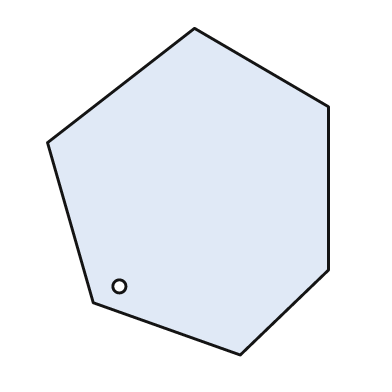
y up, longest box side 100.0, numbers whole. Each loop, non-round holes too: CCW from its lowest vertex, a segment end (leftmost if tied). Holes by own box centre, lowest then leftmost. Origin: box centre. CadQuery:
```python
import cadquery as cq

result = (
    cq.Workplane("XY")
    .moveTo(16.0, -50.0)
    .lineTo(43.0, -24.0)
    .lineTo(43.0, 26.0)
    .lineTo(2.0, 50.0)
    .lineTo(-43.0, 15.0)
    .lineTo(-29.0, -34.0)
    .close()
    .moveTo(-21.0, -29.0)
    .circle(2.0)
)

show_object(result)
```